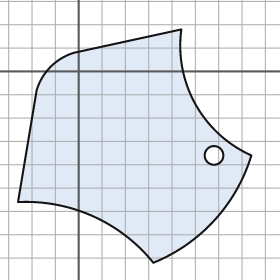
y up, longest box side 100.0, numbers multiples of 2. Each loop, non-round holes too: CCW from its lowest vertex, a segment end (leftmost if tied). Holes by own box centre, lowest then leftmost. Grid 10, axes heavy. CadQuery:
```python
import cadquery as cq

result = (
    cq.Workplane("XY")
    .moveTo(32.0, -82.0)
    .threePointArc((58.0, -64.0), (74.0, -36.0))
    .threePointArc((50.0, -14.0), (44.0, 18.0))
    .lineTo(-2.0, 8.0)
    .threePointArc((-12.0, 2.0), (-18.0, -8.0))
    .lineTo(-26.0, -56.0)
    .threePointArc((6.0, -62.0), (32.0, -82.0))
    .close()
    .moveTo(58.0, -36.0)
    .circle(4.0)
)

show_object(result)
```